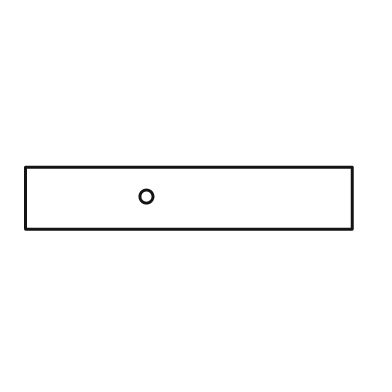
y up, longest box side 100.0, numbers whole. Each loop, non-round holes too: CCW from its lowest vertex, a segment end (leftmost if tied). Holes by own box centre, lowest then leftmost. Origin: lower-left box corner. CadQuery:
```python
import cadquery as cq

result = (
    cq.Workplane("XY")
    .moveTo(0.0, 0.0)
    .lineTo(100.0, 0.0)
    .lineTo(100.0, 19.0)
    .lineTo(0.0, 19.0)
    .close()
    .moveTo(37.0, 10.0)
    .circle(2.0)
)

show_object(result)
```